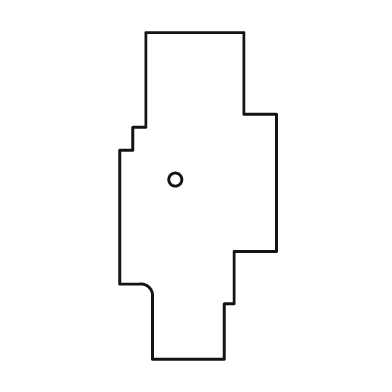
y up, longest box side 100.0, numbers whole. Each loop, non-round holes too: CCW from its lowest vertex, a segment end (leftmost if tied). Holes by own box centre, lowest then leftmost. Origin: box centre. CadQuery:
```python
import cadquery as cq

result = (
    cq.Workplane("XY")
    .moveTo(-14.0, -50.0)
    .lineTo(8.0, -50.0)
    .lineTo(8.0, -33.0)
    .lineTo(11.0, -33.0)
    .lineTo(11.0, -17.0)
    .lineTo(24.0, -17.0)
    .lineTo(24.0, 25.0)
    .lineTo(14.0, 25.0)
    .lineTo(14.0, 50.0)
    .lineTo(-16.0, 50.0)
    .lineTo(-16.0, 21.0)
    .lineTo(-20.0, 21.0)
    .lineTo(-20.0, 14.0)
    .lineTo(-24.0, 14.0)
    .lineTo(-24.0, -27.0)
    .lineTo(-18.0, -27.0)
    .threePointArc((-15.0, -28.0), (-14.0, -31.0))
    .close()
    .moveTo(-7.0, 5.0)
    .circle(2.0)
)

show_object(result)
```